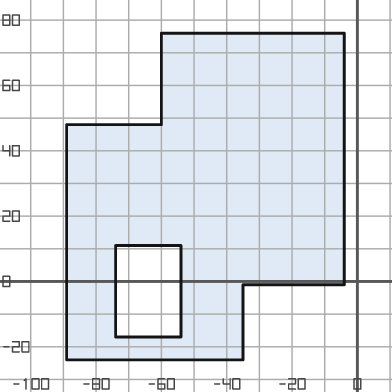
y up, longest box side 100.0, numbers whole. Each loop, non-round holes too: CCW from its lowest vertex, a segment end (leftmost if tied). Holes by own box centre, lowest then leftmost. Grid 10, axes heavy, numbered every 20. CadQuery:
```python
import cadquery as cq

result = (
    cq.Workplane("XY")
    .moveTo(-89.0, -24.0)
    .lineTo(-35.0, -24.0)
    .lineTo(-35.0, -1.0)
    .lineTo(-4.0, -1.0)
    .lineTo(-4.0, 76.0)
    .lineTo(-60.0, 76.0)
    .lineTo(-60.0, 48.0)
    .lineTo(-89.0, 48.0)
    .close()
    .moveTo(-74.0, -17.0)
    .lineTo(-54.0, -17.0)
    .lineTo(-54.0, 11.0)
    .lineTo(-74.0, 11.0)
    .close()
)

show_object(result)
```